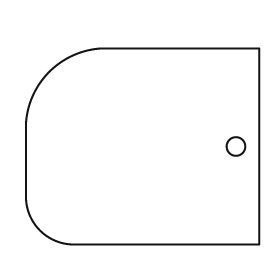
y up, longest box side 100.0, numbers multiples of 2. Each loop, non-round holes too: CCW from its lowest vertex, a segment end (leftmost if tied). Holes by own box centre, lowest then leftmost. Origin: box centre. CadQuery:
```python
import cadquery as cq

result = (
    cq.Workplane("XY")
    .moveTo(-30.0, -42.0)
    .lineTo(50.0, -42.0)
    .lineTo(50.0, 42.0)
    .lineTo(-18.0, 42.0)
    .threePointArc((-40.0, 32.0), (-50.0, 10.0))
    .lineTo(-50.0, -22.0)
    .threePointArc((-44.0, -36.0), (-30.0, -42.0))
    .close()
    .moveTo(40.0, 0.0)
    .circle(4.0)
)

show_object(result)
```